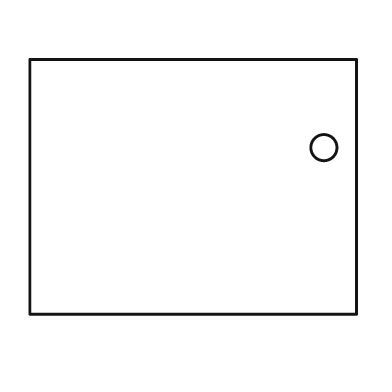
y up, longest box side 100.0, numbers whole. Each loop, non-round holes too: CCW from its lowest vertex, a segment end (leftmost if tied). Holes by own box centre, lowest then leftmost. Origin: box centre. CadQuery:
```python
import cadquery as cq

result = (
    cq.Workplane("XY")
    .moveTo(-50.0, -39.0)
    .lineTo(50.0, -39.0)
    .lineTo(50.0, 39.0)
    .lineTo(-50.0, 39.0)
    .close()
    .moveTo(40.0, 12.0)
    .circle(4.0)
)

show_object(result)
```